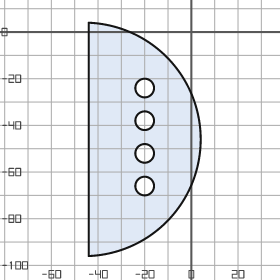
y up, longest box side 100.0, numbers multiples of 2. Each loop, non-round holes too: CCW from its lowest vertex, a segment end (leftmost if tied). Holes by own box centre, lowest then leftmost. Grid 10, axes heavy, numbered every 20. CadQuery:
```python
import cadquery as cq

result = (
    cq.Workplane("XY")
    .moveTo(-44.0, -96.0)
    .threePointArc((4.0, -46.0), (-44.0, 4.0))
    .close()
    .moveTo(-20.0, -66.0)
    .circle(4.0)
    .moveTo(-20.0, -52.0)
    .circle(4.0)
    .moveTo(-20.0, -38.0)
    .circle(4.0)
    .moveTo(-20.0, -24.0)
    .circle(4.0)
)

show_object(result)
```